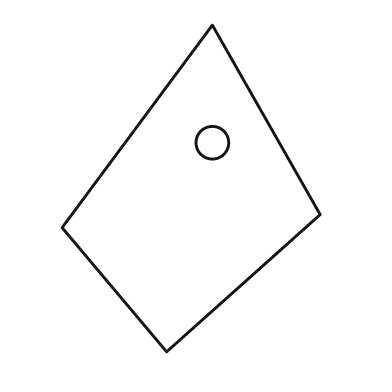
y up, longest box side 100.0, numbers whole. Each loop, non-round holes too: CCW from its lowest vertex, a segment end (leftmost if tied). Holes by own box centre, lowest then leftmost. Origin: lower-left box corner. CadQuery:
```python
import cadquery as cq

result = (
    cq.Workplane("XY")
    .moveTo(32.0, 0.0)
    .lineTo(79.0, 42.0)
    .lineTo(46.0, 100.0)
    .lineTo(0.0, 38.0)
    .close()
    .moveTo(46.0, 64.0)
    .circle(5.0)
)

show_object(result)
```